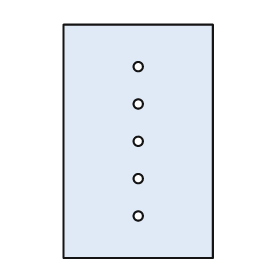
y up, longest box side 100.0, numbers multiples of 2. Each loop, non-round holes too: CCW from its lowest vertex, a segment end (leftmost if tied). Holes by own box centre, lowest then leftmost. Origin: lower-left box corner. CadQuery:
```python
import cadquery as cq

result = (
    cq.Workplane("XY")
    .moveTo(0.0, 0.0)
    .lineTo(64.0, 0.0)
    .lineTo(64.0, 100.0)
    .lineTo(0.0, 100.0)
    .close()
    .moveTo(32.0, 18.0)
    .circle(2.0)
    .moveTo(32.0, 34.0)
    .circle(2.0)
    .moveTo(32.0, 50.0)
    .circle(2.0)
    .moveTo(32.0, 66.0)
    .circle(2.0)
    .moveTo(32.0, 82.0)
    .circle(2.0)
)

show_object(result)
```